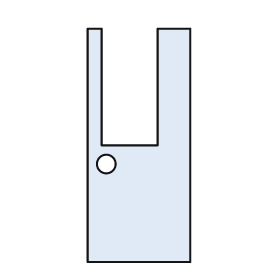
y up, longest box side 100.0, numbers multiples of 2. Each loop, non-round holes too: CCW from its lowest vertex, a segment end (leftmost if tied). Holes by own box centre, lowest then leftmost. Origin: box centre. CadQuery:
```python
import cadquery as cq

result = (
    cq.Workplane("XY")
    .moveTo(-22.0, -50.0)
    .lineTo(22.0, -50.0)
    .lineTo(22.0, 50.0)
    .lineTo(8.0, 50.0)
    .lineTo(8.0, 0.0)
    .lineTo(-16.0, 0.0)
    .lineTo(-16.0, 50.0)
    .lineTo(-22.0, 50.0)
    .close()
    .moveTo(-14.0, -8.0)
    .circle(4.0)
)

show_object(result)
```